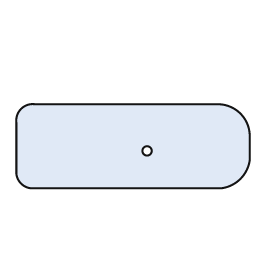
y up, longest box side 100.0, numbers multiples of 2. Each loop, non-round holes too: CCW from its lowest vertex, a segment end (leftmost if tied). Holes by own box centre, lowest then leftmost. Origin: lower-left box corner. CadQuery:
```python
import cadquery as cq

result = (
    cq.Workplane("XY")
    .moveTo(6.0, 0.0)
    .lineTo(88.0, 0.0)
    .threePointArc((96.0, 4.0), (100.0, 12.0))
    .lineTo(100.0, 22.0)
    .threePointArc((96.0, 32.0), (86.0, 36.0))
    .lineTo(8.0, 36.0)
    .threePointArc((2.0, 34.0), (0.0, 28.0))
    .lineTo(0.0, 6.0)
    .threePointArc((2.0, 2.0), (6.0, 0.0))
    .close()
    .moveTo(56.0, 16.0)
    .circle(2.0)
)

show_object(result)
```